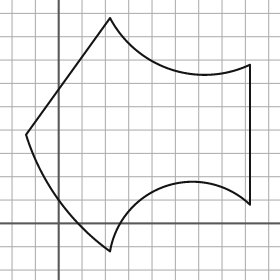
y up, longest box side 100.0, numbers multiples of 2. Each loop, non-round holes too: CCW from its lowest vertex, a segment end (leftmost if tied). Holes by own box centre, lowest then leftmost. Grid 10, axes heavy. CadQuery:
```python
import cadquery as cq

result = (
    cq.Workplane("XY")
    .moveTo(22.0, -12.0)
    .threePointArc((46.0, 16.0), (82.0, 8.0))
    .lineTo(82.0, 68.0)
    .threePointArc((48.0, 66.0), (22.0, 88.0))
    .lineTo(-14.0, 38.0)
    .threePointArc((0.0, 10.0), (22.0, -12.0))
    .close()
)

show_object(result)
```